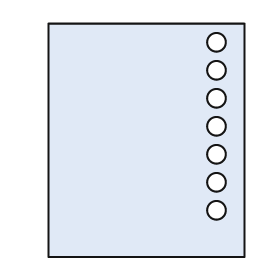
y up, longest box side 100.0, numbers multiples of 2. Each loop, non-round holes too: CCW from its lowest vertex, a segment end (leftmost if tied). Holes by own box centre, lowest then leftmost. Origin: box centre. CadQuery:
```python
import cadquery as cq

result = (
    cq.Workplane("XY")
    .moveTo(-42.0, -50.0)
    .lineTo(42.0, -50.0)
    .lineTo(42.0, 50.0)
    .lineTo(-42.0, 50.0)
    .close()
    .moveTo(30.0, -30.0)
    .circle(4.0)
    .moveTo(30.0, -18.0)
    .circle(4.0)
    .moveTo(30.0, -6.0)
    .circle(4.0)
    .moveTo(30.0, 6.0)
    .circle(4.0)
    .moveTo(30.0, 18.0)
    .circle(4.0)
    .moveTo(30.0, 30.0)
    .circle(4.0)
    .moveTo(30.0, 42.0)
    .circle(4.0)
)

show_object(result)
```